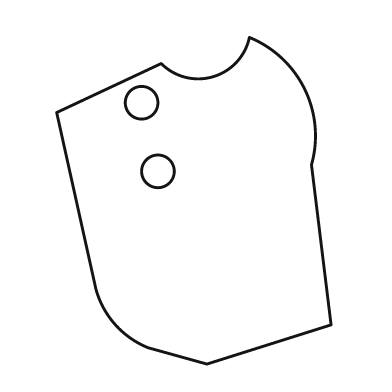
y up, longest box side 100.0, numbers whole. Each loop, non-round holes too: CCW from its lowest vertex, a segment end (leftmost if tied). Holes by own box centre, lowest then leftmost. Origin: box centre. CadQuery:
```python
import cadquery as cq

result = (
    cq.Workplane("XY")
    .moveTo(4.0, -50.0)
    .lineTo(42.0, -38.0)
    .lineTo(36.0, 11.0)
    .threePointArc((34.0, 34.0), (17.0, 50.0))
    .threePointArc((6.0, 38.0), (-10.0, 42.0))
    .lineTo(-42.0, 27.0)
    .lineTo(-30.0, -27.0)
    .threePointArc((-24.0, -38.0), (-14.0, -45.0))
    .close()
    .moveTo(-11.0, 9.0)
    .circle(5.0)
    .moveTo(-16.0, 30.0)
    .circle(5.0)
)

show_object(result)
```